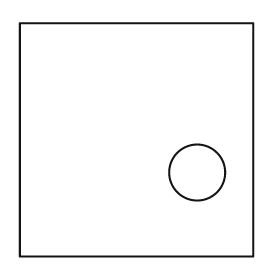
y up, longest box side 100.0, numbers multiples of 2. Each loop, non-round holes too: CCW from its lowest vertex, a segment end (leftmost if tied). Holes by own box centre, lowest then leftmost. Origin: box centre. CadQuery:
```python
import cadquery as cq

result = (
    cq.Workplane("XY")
    .moveTo(-50.0, -50.0)
    .lineTo(50.0, -50.0)
    .lineTo(50.0, 50.0)
    .lineTo(-50.0, 50.0)
    .close()
    .moveTo(26.0, -14.0)
    .circle(12.0)
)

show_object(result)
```